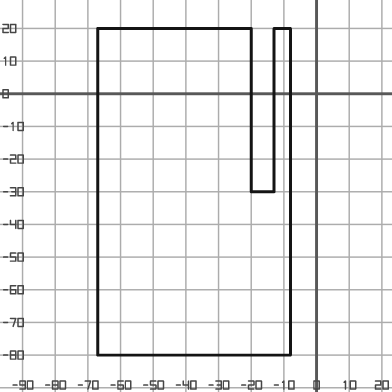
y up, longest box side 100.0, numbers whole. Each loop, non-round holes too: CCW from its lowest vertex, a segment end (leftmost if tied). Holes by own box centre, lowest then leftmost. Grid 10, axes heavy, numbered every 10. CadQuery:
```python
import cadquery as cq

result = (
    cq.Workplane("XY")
    .moveTo(-67.0, -80.0)
    .lineTo(-8.0, -80.0)
    .lineTo(-8.0, 20.0)
    .lineTo(-13.0, 20.0)
    .lineTo(-13.0, -30.0)
    .lineTo(-20.0, -30.0)
    .lineTo(-20.0, 20.0)
    .lineTo(-67.0, 20.0)
    .close()
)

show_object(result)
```